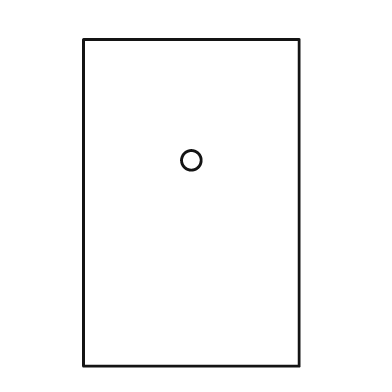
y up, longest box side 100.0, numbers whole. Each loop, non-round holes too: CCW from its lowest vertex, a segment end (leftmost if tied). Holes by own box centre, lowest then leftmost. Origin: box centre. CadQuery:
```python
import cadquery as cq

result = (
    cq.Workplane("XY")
    .moveTo(-33.0, -50.0)
    .lineTo(33.0, -50.0)
    .lineTo(33.0, 50.0)
    .lineTo(-33.0, 50.0)
    .close()
    .moveTo(0.0, 13.0)
    .circle(3.0)
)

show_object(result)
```